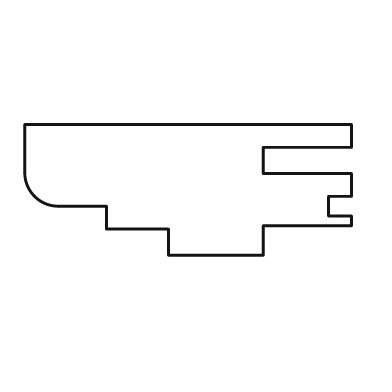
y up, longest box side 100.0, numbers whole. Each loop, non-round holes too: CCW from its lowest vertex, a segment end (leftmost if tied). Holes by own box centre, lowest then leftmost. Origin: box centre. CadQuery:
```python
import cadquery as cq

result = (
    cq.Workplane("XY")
    .moveTo(-6.0, -20.0)
    .lineTo(23.0, -20.0)
    .lineTo(23.0, -11.0)
    .lineTo(50.0, -11.0)
    .lineTo(50.0, -8.0)
    .lineTo(43.0, -8.0)
    .lineTo(43.0, -2.0)
    .lineTo(50.0, -2.0)
    .lineTo(50.0, 5.0)
    .lineTo(23.0, 5.0)
    .lineTo(23.0, 13.0)
    .lineTo(50.0, 13.0)
    .lineTo(50.0, 20.0)
    .lineTo(-50.0, 20.0)
    .lineTo(-50.0, 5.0)
    .threePointArc((-47.0, -2.0), (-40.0, -5.0))
    .lineTo(-25.0, -5.0)
    .lineTo(-25.0, -12.0)
    .lineTo(-6.0, -12.0)
    .close()
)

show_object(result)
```